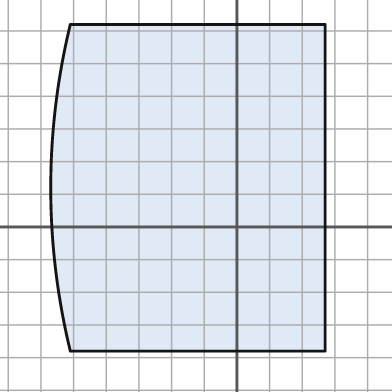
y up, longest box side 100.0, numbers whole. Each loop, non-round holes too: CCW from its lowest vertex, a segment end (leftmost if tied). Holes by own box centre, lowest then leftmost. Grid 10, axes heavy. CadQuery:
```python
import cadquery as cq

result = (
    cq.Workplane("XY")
    .moveTo(-51.0, -38.0)
    .lineTo(27.0, -38.0)
    .lineTo(27.0, 62.0)
    .lineTo(-51.0, 62.0)
    .threePointArc((-57.0, 12.0), (-51.0, -38.0))
    .close()
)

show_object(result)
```